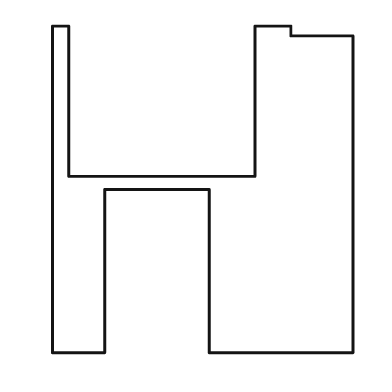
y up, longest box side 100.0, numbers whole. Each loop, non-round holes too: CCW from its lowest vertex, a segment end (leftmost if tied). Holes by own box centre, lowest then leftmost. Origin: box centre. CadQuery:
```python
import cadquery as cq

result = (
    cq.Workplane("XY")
    .moveTo(-46.0, -50.0)
    .lineTo(-30.0, -50.0)
    .lineTo(-30.0, 0.0)
    .lineTo(2.0, 0.0)
    .lineTo(2.0, -50.0)
    .lineTo(46.0, -50.0)
    .lineTo(46.0, 47.0)
    .lineTo(27.0, 47.0)
    .lineTo(27.0, 50.0)
    .lineTo(16.0, 50.0)
    .lineTo(16.0, 4.0)
    .lineTo(-41.0, 4.0)
    .lineTo(-41.0, 50.0)
    .lineTo(-46.0, 50.0)
    .close()
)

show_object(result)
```